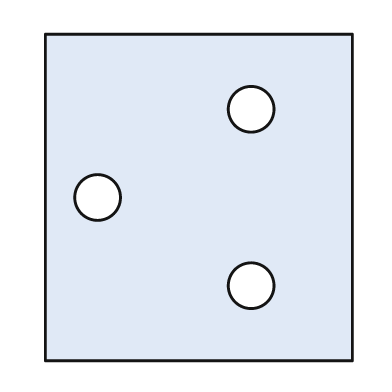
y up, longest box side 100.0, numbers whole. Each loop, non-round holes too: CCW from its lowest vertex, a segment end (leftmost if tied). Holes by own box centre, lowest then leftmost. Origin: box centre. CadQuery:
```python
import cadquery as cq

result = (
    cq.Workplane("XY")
    .moveTo(-47.0, -50.0)
    .lineTo(47.0, -50.0)
    .lineTo(47.0, 50.0)
    .lineTo(-47.0, 50.0)
    .close()
    .moveTo(16.0, -27.0)
    .circle(7.0)
    .moveTo(-31.0, 0.0)
    .circle(7.0)
    .moveTo(16.0, 27.0)
    .circle(7.0)
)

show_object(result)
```